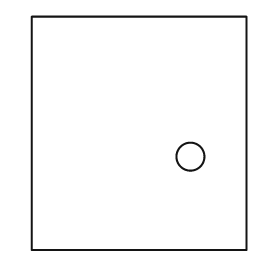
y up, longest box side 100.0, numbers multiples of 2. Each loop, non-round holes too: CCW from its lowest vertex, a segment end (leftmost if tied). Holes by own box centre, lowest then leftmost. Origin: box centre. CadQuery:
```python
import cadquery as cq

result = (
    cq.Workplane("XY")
    .moveTo(-46.0, -50.0)
    .lineTo(46.0, -50.0)
    .lineTo(46.0, 50.0)
    .lineTo(-46.0, 50.0)
    .close()
    .moveTo(22.0, -10.0)
    .circle(6.0)
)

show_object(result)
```